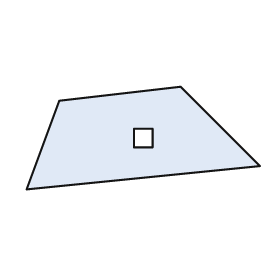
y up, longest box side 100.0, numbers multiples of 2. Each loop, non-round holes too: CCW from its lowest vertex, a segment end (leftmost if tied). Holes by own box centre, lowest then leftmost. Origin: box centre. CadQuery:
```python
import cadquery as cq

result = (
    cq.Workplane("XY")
    .moveTo(-50.0, -22.0)
    .lineTo(50.0, -12.0)
    .lineTo(16.0, 22.0)
    .lineTo(-36.0, 16.0)
    .close()
    .moveTo(-4.0, -4.0)
    .lineTo(4.0, -4.0)
    .lineTo(4.0, 4.0)
    .lineTo(-4.0, 4.0)
    .close()
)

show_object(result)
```